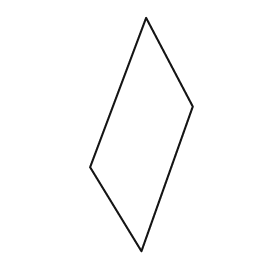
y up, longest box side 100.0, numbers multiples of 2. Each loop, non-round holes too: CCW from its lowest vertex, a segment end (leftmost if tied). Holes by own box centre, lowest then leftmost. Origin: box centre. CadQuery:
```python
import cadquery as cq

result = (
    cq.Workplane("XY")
    .moveTo(0.0, -50.0)
    .lineTo(22.0, 12.0)
    .lineTo(2.0, 50.0)
    .lineTo(-22.0, -14.0)
    .close()
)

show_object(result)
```